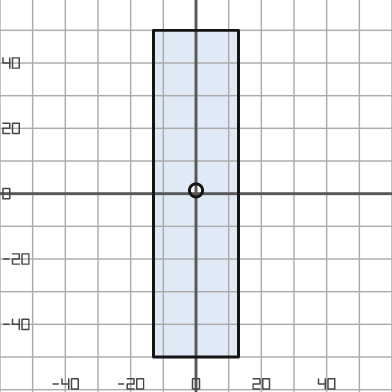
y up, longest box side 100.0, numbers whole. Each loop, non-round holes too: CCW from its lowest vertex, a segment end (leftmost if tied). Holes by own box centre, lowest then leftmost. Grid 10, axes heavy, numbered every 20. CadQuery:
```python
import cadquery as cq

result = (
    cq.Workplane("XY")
    .moveTo(-13.0, -50.0)
    .lineTo(13.0, -50.0)
    .lineTo(13.0, 50.0)
    .lineTo(-13.0, 50.0)
    .close()
    .moveTo(0.0, 1.0)
    .circle(2.0)
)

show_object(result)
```